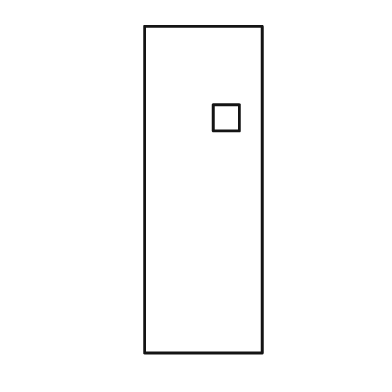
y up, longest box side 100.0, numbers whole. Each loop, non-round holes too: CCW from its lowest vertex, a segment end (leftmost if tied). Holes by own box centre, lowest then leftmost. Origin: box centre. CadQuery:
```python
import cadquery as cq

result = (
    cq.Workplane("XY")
    .moveTo(-18.0, -50.0)
    .lineTo(18.0, -50.0)
    .lineTo(18.0, 50.0)
    .lineTo(-18.0, 50.0)
    .close()
    .moveTo(3.0, 18.0)
    .lineTo(11.0, 18.0)
    .lineTo(11.0, 26.0)
    .lineTo(3.0, 26.0)
    .close()
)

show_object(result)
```